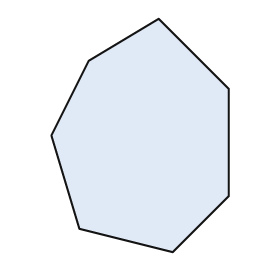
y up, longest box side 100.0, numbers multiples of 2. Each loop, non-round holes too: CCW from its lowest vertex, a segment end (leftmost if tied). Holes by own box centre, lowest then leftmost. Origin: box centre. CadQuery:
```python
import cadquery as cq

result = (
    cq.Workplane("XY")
    .moveTo(14.0, -50.0)
    .lineTo(38.0, -26.0)
    .lineTo(38.0, 20.0)
    .lineTo(8.0, 50.0)
    .lineTo(-22.0, 32.0)
    .lineTo(-38.0, 0.0)
    .lineTo(-26.0, -40.0)
    .close()
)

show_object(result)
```